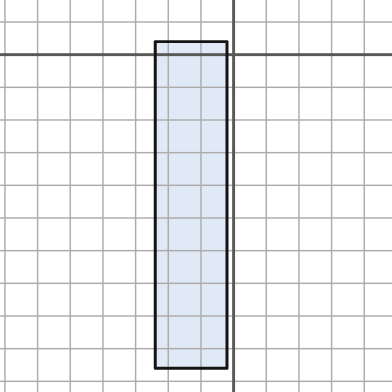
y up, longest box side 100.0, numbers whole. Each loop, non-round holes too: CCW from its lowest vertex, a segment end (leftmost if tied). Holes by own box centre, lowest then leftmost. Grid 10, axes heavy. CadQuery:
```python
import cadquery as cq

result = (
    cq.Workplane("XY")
    .moveTo(-24.0, -96.0)
    .lineTo(-2.0, -96.0)
    .lineTo(-2.0, 4.0)
    .lineTo(-24.0, 4.0)
    .close()
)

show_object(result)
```